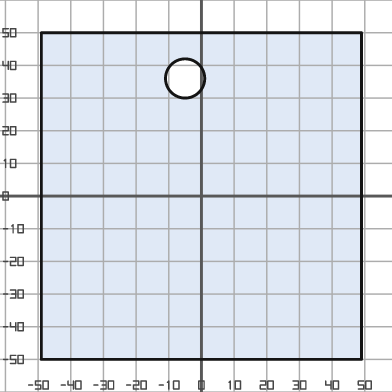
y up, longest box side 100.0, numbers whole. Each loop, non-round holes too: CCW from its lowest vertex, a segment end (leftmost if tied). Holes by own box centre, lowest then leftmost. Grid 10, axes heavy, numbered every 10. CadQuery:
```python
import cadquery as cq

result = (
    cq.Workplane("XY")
    .moveTo(-49.0, -50.0)
    .lineTo(49.0, -50.0)
    .lineTo(49.0, 50.0)
    .lineTo(-49.0, 50.0)
    .close()
    .moveTo(-5.0, 36.0)
    .circle(6.0)
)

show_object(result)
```